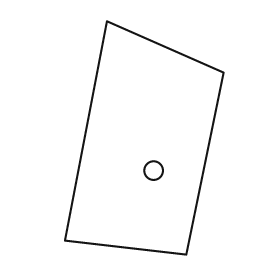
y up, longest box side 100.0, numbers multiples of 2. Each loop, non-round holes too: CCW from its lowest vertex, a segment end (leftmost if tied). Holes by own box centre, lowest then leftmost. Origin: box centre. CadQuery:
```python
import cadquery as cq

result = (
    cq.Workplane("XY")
    .moveTo(18.0, -50.0)
    .lineTo(34.0, 28.0)
    .lineTo(-16.0, 50.0)
    .lineTo(-34.0, -44.0)
    .close()
    .moveTo(4.0, -14.0)
    .circle(4.0)
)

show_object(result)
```